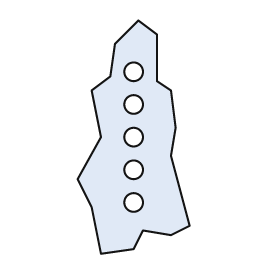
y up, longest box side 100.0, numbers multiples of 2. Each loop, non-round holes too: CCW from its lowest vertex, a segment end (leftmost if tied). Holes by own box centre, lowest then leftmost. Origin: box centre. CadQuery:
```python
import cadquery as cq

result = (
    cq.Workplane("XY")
    .moveTo(-14.0, -50.0)
    .lineTo(0.0, -48.0)
    .lineTo(4.0, -40.0)
    .lineTo(16.0, -42.0)
    .lineTo(24.0, -38.0)
    .lineTo(16.0, -8.0)
    .lineTo(18.0, 4.0)
    .lineTo(16.0, 20.0)
    .lineTo(10.0, 24.0)
    .lineTo(10.0, 44.0)
    .lineTo(2.0, 50.0)
    .lineTo(-8.0, 40.0)
    .lineTo(-10.0, 26.0)
    .lineTo(-18.0, 20.0)
    .lineTo(-14.0, 0.0)
    .lineTo(-24.0, -18.0)
    .lineTo(-18.0, -30.0)
    .close()
    .moveTo(0.0, -28.0)
    .circle(4.0)
    .moveTo(0.0, -14.0)
    .circle(4.0)
    .moveTo(0.0, 0.0)
    .circle(4.0)
    .moveTo(0.0, 14.0)
    .circle(4.0)
    .moveTo(0.0, 28.0)
    .circle(4.0)
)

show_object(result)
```